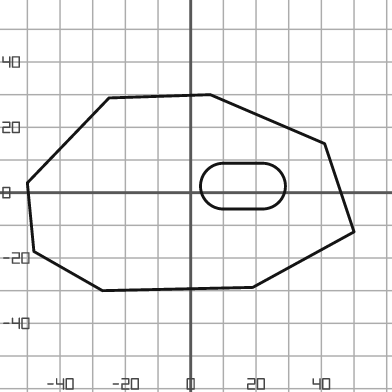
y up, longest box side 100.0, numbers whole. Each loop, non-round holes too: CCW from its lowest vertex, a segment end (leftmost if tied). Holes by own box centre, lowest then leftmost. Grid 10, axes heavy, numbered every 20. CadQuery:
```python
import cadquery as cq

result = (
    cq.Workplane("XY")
    .moveTo(-27.0, -30.0)
    .lineTo(19.0, -29.0)
    .lineTo(50.0, -12.0)
    .lineTo(41.0, 15.0)
    .lineTo(6.0, 30.0)
    .lineTo(-25.0, 29.0)
    .lineTo(-50.0, 3.0)
    .lineTo(-48.0, -18.0)
    .close()
    .moveTo(10.0, -5.0)
    .lineTo(22.0, -5.0)
    .threePointArc((29.0, 2.0), (22.0, 9.0))
    .lineTo(10.0, 9.0)
    .threePointArc((3.0, 2.0), (10.0, -5.0))
    .close()
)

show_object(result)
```